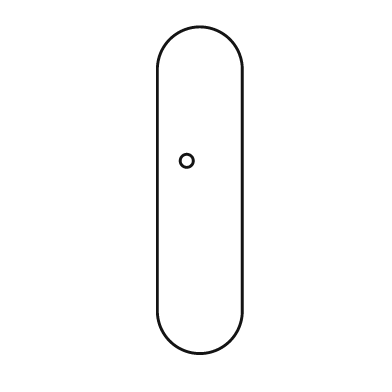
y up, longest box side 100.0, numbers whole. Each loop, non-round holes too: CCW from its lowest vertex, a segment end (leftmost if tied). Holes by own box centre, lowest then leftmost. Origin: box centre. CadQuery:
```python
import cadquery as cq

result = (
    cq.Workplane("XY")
    .moveTo(-13.0, -37.0)
    .threePointArc((0.0, -50.0), (13.0, -37.0))
    .lineTo(13.0, 37.0)
    .threePointArc((0.0, 50.0), (-13.0, 37.0))
    .close()
    .moveTo(-4.0, 9.0)
    .circle(2.0)
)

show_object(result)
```